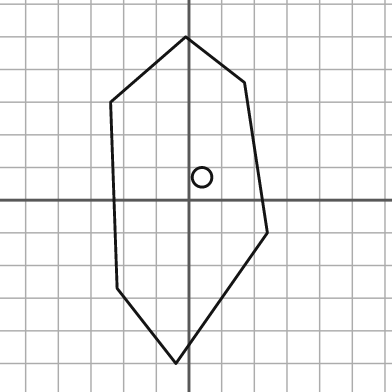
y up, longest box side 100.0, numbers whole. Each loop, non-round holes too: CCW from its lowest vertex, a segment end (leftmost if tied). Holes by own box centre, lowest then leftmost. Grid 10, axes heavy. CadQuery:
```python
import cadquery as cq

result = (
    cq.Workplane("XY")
    .moveTo(-4.0, -50.0)
    .lineTo(24.0, -10.0)
    .lineTo(17.0, 36.0)
    .lineTo(-1.0, 50.0)
    .lineTo(-24.0, 30.0)
    .lineTo(-22.0, -27.0)
    .close()
    .moveTo(4.0, 7.0)
    .circle(3.0)
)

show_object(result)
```